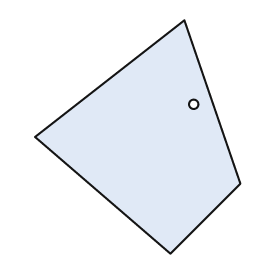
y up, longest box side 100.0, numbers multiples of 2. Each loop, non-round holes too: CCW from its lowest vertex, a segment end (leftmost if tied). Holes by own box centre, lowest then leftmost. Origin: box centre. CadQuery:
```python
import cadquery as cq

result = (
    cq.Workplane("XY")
    .moveTo(14.0, -50.0)
    .lineTo(44.0, -20.0)
    .lineTo(20.0, 50.0)
    .lineTo(-44.0, 0.0)
    .close()
    .moveTo(24.0, 14.0)
    .circle(2.0)
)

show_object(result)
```